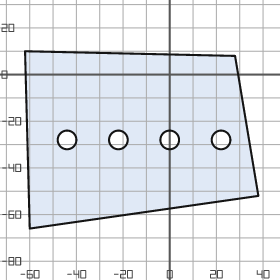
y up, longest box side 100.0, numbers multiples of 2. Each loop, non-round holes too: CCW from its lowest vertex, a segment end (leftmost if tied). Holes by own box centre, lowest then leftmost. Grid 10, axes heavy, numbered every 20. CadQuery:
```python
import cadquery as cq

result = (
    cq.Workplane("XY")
    .moveTo(-60.0, -66.0)
    .lineTo(38.0, -52.0)
    .lineTo(28.0, 8.0)
    .lineTo(-62.0, 10.0)
    .close()
    .moveTo(-44.0, -28.0)
    .circle(4.0)
    .moveTo(-22.0, -28.0)
    .circle(4.0)
    .moveTo(0.0, -28.0)
    .circle(4.0)
    .moveTo(22.0, -28.0)
    .circle(4.0)
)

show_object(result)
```